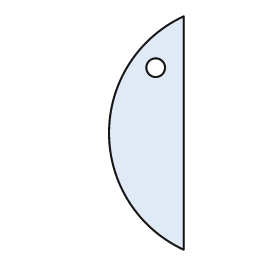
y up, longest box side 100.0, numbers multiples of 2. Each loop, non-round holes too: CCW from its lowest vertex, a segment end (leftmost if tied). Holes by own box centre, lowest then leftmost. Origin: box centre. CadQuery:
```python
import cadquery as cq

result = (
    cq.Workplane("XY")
    .moveTo(16.0, -50.0)
    .lineTo(16.0, 50.0)
    .threePointArc((-16.0, 0.0), (16.0, -50.0))
    .close()
    .moveTo(4.0, 28.0)
    .circle(4.0)
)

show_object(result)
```